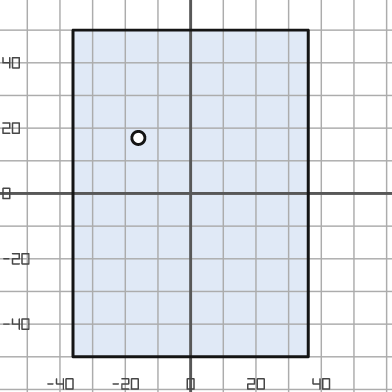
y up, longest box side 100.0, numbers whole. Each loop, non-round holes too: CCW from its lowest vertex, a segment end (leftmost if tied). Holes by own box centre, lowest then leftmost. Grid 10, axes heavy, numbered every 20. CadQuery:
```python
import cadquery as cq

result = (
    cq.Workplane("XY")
    .moveTo(-36.0, -50.0)
    .lineTo(36.0, -50.0)
    .lineTo(36.0, 50.0)
    .lineTo(-36.0, 50.0)
    .close()
    .moveTo(-16.0, 17.0)
    .circle(2.0)
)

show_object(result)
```